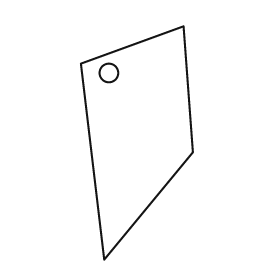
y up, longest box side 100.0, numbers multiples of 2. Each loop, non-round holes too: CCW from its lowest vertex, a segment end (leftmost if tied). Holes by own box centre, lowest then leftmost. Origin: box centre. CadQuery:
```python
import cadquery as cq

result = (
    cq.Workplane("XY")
    .moveTo(-14.0, -50.0)
    .lineTo(24.0, -4.0)
    .lineTo(20.0, 50.0)
    .lineTo(-24.0, 34.0)
    .close()
    .moveTo(-12.0, 30.0)
    .circle(4.0)
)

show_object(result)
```